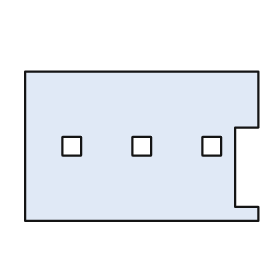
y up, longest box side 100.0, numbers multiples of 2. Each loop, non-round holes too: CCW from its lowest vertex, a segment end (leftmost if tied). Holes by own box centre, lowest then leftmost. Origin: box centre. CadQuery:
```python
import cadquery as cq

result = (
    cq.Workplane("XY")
    .moveTo(-50.0, -32.0)
    .lineTo(50.0, -32.0)
    .lineTo(50.0, -26.0)
    .lineTo(40.0, -26.0)
    .lineTo(40.0, 8.0)
    .lineTo(50.0, 8.0)
    .lineTo(50.0, 32.0)
    .lineTo(-50.0, 32.0)
    .close()
    .moveTo(-34.0, -4.0)
    .lineTo(-26.0, -4.0)
    .lineTo(-26.0, 4.0)
    .lineTo(-34.0, 4.0)
    .close()
    .moveTo(-4.0, -4.0)
    .lineTo(4.0, -4.0)
    .lineTo(4.0, 4.0)
    .lineTo(-4.0, 4.0)
    .close()
    .moveTo(26.0, -4.0)
    .lineTo(34.0, -4.0)
    .lineTo(34.0, 4.0)
    .lineTo(26.0, 4.0)
    .close()
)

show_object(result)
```